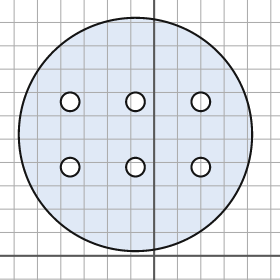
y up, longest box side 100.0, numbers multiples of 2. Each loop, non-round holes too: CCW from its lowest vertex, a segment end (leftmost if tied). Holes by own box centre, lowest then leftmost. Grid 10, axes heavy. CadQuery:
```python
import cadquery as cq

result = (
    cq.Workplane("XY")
    .moveTo(-8.0, 52.0)
    .circle(50.0)
    .moveTo(-36.0, 38.0)
    .circle(4.0)
    .moveTo(-8.0, 38.0)
    .circle(4.0)
    .moveTo(20.0, 38.0)
    .circle(4.0)
    .moveTo(-36.0, 66.0)
    .circle(4.0)
    .moveTo(-8.0, 66.0)
    .circle(4.0)
    .moveTo(20.0, 66.0)
    .circle(4.0)
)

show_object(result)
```